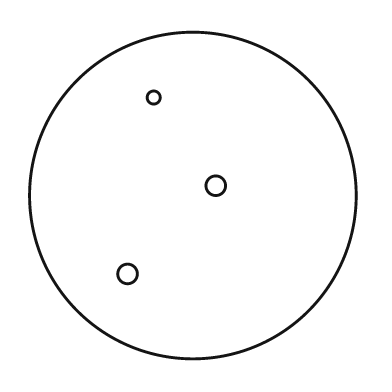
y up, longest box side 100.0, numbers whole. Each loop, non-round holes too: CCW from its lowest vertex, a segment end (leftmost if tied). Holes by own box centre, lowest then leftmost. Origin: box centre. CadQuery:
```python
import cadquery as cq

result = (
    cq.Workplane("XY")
    .moveTo(0.0, 0.0)
    .circle(50.0)
    .moveTo(-20.0, -24.0)
    .circle(3.0)
    .moveTo(7.0, 3.0)
    .circle(3.0)
    .moveTo(-12.0, 30.0)
    .circle(2.0)
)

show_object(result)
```